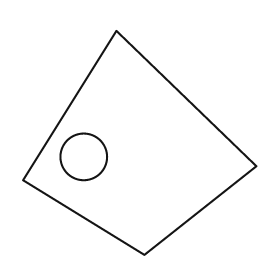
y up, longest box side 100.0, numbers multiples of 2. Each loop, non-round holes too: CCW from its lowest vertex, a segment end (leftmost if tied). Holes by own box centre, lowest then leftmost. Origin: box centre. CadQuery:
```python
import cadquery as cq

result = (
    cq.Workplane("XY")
    .moveTo(2.0, -48.0)
    .lineTo(50.0, -10.0)
    .lineTo(-10.0, 48.0)
    .lineTo(-50.0, -16.0)
    .close()
    .moveTo(-24.0, -6.0)
    .circle(10.0)
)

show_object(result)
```